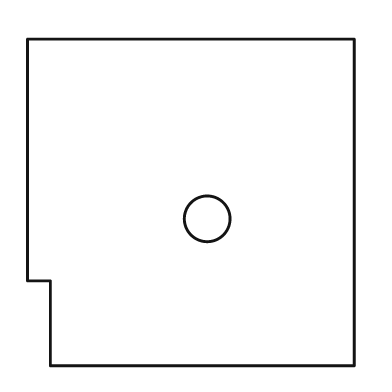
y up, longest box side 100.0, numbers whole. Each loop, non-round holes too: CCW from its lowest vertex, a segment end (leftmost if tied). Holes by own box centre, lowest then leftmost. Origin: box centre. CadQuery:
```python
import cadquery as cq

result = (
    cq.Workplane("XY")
    .moveTo(-43.0, -50.0)
    .lineTo(50.0, -50.0)
    .lineTo(50.0, 50.0)
    .lineTo(-50.0, 50.0)
    .lineTo(-50.0, -24.0)
    .lineTo(-43.0, -24.0)
    .close()
    .moveTo(5.0, -5.0)
    .circle(7.0)
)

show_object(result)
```